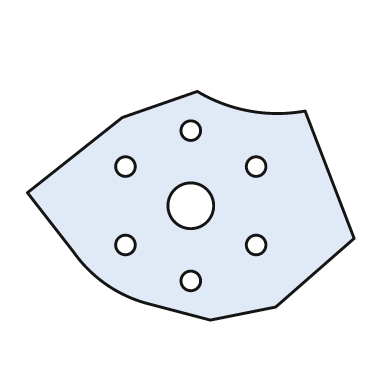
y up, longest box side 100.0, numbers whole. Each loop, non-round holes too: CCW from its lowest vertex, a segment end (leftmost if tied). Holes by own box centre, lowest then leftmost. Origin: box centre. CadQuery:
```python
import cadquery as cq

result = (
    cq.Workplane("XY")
    .moveTo(6.0, -35.0)
    .lineTo(26.0, -31.0)
    .lineTo(50.0, -10.0)
    .lineTo(35.0, 29.0)
    .threePointArc((18.0, 29.0), (2.0, 35.0))
    .lineTo(-21.0, 27.0)
    .lineTo(-50.0, 4.0)
    .lineTo(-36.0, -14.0)
    .threePointArc((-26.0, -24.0), (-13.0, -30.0))
    .close()
    .moveTo(0.0, -23.0)
    .circle(3.0)
    .moveTo(-20.0, -12.0)
    .circle(3.0)
    .moveTo(20.0, -12.0)
    .circle(3.0)
    .moveTo(0.0, 0.0)
    .circle(7.0)
    .moveTo(-20.0, 12.0)
    .circle(3.0)
    .moveTo(20.0, 12.0)
    .circle(3.0)
    .moveTo(0.0, 23.0)
    .circle(3.0)
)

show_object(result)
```